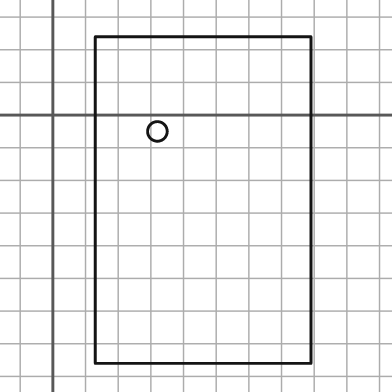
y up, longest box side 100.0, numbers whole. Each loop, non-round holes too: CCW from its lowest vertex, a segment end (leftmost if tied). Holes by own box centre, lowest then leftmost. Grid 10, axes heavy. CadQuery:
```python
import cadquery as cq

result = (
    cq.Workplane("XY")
    .moveTo(13.0, -76.0)
    .lineTo(79.0, -76.0)
    .lineTo(79.0, 24.0)
    .lineTo(13.0, 24.0)
    .close()
    .moveTo(32.0, -5.0)
    .circle(3.0)
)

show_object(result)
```